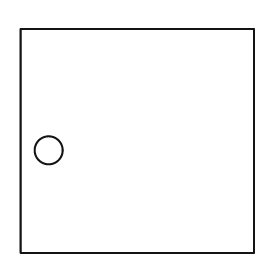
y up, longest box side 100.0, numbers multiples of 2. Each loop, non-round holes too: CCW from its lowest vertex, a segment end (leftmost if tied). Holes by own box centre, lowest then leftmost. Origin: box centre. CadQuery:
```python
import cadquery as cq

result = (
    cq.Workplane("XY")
    .moveTo(-50.0, -48.0)
    .lineTo(50.0, -48.0)
    .lineTo(50.0, 48.0)
    .lineTo(-50.0, 48.0)
    .close()
    .moveTo(-38.0, -4.0)
    .circle(6.0)
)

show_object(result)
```